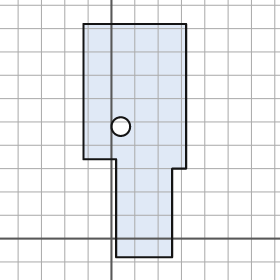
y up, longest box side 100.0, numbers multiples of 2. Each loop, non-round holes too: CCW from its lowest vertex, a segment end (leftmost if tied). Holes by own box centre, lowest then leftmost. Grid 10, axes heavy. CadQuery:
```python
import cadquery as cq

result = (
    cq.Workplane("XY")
    .moveTo(2.0, -8.0)
    .lineTo(26.0, -8.0)
    .lineTo(26.0, 30.0)
    .lineTo(32.0, 30.0)
    .lineTo(32.0, 92.0)
    .lineTo(-12.0, 92.0)
    .lineTo(-12.0, 34.0)
    .lineTo(2.0, 34.0)
    .close()
    .moveTo(4.0, 48.0)
    .circle(4.0)
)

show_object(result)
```